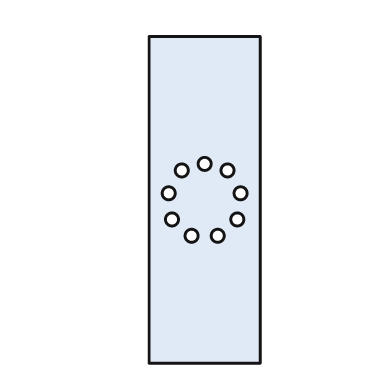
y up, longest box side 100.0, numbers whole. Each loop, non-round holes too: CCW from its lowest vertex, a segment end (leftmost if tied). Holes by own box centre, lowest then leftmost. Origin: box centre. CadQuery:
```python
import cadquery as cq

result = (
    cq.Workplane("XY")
    .moveTo(-17.0, -50.0)
    .lineTo(17.0, -50.0)
    .lineTo(17.0, 50.0)
    .lineTo(-17.0, 50.0)
    .close()
    .moveTo(-4.0, -11.0)
    .circle(2.0)
    .moveTo(4.0, -11.0)
    .circle(2.0)
    .moveTo(-10.0, -6.0)
    .circle(2.0)
    .moveTo(10.0, -6.0)
    .circle(2.0)
    .moveTo(-11.0, 2.0)
    .circle(2.0)
    .moveTo(11.0, 2.0)
    .circle(2.0)
    .moveTo(-7.0, 9.0)
    .circle(2.0)
    .moveTo(7.0, 9.0)
    .circle(2.0)
    .moveTo(0.0, 11.0)
    .circle(2.0)
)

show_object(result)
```